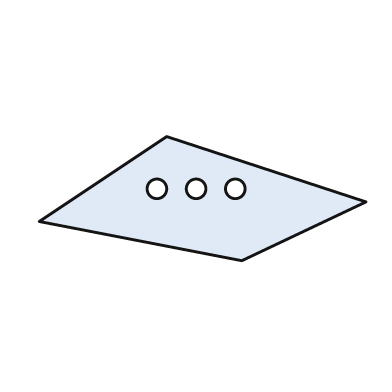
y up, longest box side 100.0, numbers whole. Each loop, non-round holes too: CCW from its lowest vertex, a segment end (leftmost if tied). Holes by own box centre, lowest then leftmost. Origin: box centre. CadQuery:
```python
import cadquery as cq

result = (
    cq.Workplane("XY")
    .moveTo(12.0, -19.0)
    .lineTo(50.0, -1.0)
    .lineTo(-11.0, 19.0)
    .lineTo(-50.0, -7.0)
    .close()
    .moveTo(-14.0, 3.0)
    .circle(3.0)
    .moveTo(-2.0, 3.0)
    .circle(3.0)
    .moveTo(10.0, 3.0)
    .circle(3.0)
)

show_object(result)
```